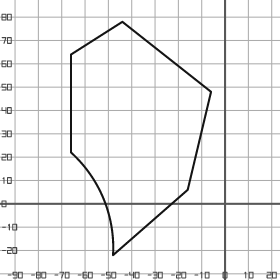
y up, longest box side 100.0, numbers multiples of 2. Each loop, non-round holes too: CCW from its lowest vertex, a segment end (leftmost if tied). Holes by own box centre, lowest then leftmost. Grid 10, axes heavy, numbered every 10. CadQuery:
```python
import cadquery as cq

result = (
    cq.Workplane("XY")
    .moveTo(-48.0, -22.0)
    .lineTo(-16.0, 6.0)
    .lineTo(-6.0, 48.0)
    .lineTo(-44.0, 78.0)
    .lineTo(-66.0, 64.0)
    .lineTo(-66.0, 22.0)
    .threePointArc((-52.0, 2.0), (-48.0, -22.0))
    .close()
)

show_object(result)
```